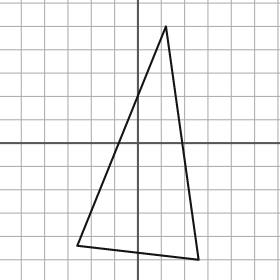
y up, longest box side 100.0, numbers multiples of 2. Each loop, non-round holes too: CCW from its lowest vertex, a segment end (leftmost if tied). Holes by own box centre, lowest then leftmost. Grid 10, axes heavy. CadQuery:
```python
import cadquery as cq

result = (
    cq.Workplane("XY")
    .moveTo(26.0, -50.0)
    .lineTo(12.0, 50.0)
    .lineTo(-26.0, -44.0)
    .close()
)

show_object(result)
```